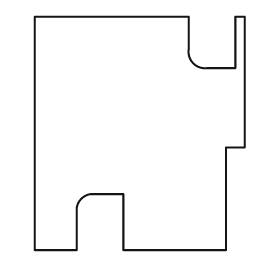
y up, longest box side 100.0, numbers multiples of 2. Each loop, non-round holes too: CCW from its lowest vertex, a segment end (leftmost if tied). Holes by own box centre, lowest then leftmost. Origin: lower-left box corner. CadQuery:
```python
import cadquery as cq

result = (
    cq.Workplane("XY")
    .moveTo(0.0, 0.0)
    .lineTo(18.0, 0.0)
    .lineTo(18.0, 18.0)
    .threePointArc((20.0, 22.0), (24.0, 24.0))
    .lineTo(38.0, 24.0)
    .lineTo(38.0, 0.0)
    .lineTo(82.0, 0.0)
    .lineTo(82.0, 44.0)
    .lineTo(90.0, 44.0)
    .lineTo(90.0, 100.0)
    .lineTo(86.0, 100.0)
    .lineTo(86.0, 78.0)
    .lineTo(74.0, 78.0)
    .threePointArc((68.0, 80.0), (66.0, 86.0))
    .lineTo(66.0, 100.0)
    .lineTo(0.0, 100.0)
    .close()
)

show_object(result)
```